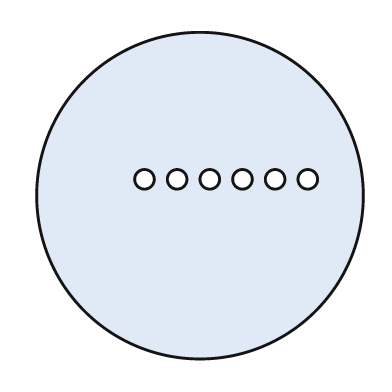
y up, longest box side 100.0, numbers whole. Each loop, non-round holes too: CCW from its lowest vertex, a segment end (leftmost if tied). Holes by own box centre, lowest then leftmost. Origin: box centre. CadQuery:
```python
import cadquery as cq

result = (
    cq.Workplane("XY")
    .moveTo(0.0, 0.0)
    .circle(50.0)
    .moveTo(-17.0, 5.0)
    .circle(3.0)
    .moveTo(-7.0, 5.0)
    .circle(3.0)
    .moveTo(3.0, 5.0)
    .circle(3.0)
    .moveTo(13.0, 5.0)
    .circle(3.0)
    .moveTo(23.0, 5.0)
    .circle(3.0)
    .moveTo(33.0, 5.0)
    .circle(3.0)
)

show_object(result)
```